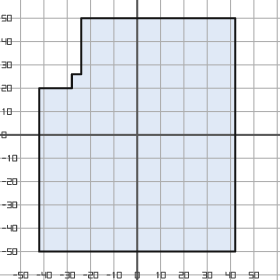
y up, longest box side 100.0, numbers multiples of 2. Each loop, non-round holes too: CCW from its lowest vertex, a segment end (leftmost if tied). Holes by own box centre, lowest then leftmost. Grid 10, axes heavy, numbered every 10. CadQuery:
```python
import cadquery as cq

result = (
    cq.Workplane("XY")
    .moveTo(-42.0, -50.0)
    .lineTo(42.0, -50.0)
    .lineTo(42.0, 50.0)
    .lineTo(-24.0, 50.0)
    .lineTo(-24.0, 26.0)
    .lineTo(-28.0, 26.0)
    .lineTo(-28.0, 20.0)
    .lineTo(-42.0, 20.0)
    .close()
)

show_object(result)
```